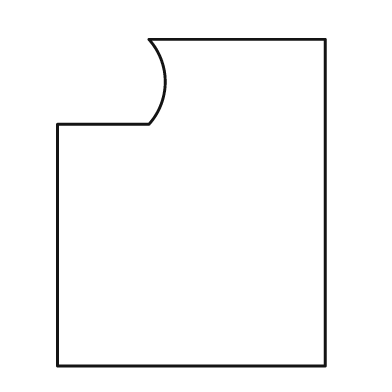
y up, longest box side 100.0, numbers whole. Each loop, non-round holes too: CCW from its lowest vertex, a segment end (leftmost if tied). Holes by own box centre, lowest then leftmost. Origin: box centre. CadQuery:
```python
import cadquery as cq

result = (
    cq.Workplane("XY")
    .moveTo(-41.0, -50.0)
    .lineTo(41.0, -50.0)
    .lineTo(41.0, 50.0)
    .lineTo(-13.0, 50.0)
    .threePointArc((-8.0, 37.0), (-13.0, 24.0))
    .lineTo(-41.0, 24.0)
    .close()
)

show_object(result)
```